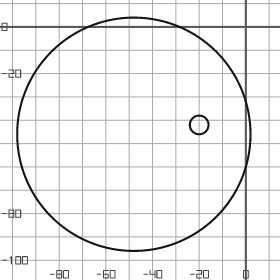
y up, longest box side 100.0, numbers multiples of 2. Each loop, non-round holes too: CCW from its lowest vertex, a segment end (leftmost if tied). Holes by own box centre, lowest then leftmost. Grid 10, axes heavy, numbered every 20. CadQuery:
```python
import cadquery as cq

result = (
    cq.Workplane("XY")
    .moveTo(-48.0, -46.0)
    .circle(50.0)
    .moveTo(-20.0, -42.0)
    .circle(4.0)
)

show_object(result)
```